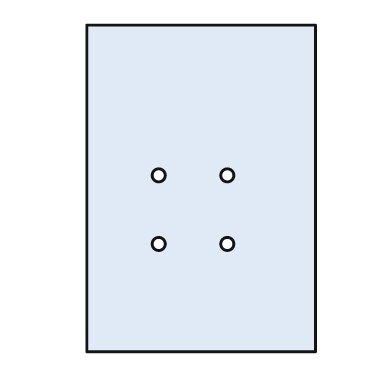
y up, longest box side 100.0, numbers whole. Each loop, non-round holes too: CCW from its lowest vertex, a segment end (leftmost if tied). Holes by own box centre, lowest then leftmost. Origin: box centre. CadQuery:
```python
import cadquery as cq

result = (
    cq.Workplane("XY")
    .moveTo(-35.0, -50.0)
    .lineTo(35.0, -50.0)
    .lineTo(35.0, 50.0)
    .lineTo(-35.0, 50.0)
    .close()
    .moveTo(-13.0, -17.0)
    .circle(2.0)
    .moveTo(8.0, -17.0)
    .circle(2.0)
    .moveTo(-13.0, 4.0)
    .circle(2.0)
    .moveTo(8.0, 4.0)
    .circle(2.0)
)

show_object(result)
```